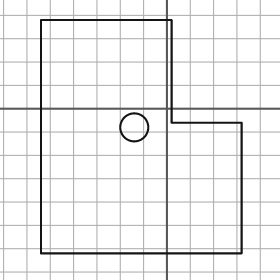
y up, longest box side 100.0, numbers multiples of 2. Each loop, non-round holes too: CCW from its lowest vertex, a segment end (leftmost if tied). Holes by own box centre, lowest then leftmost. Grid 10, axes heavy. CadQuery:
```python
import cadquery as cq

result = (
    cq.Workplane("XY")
    .moveTo(-54.0, -62.0)
    .lineTo(32.0, -62.0)
    .lineTo(32.0, -6.0)
    .lineTo(2.0, -6.0)
    .lineTo(2.0, 38.0)
    .lineTo(-54.0, 38.0)
    .close()
    .moveTo(-14.0, -8.0)
    .circle(6.0)
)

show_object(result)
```